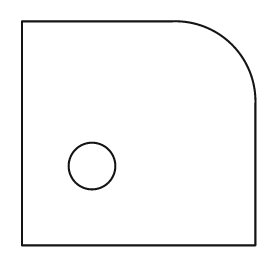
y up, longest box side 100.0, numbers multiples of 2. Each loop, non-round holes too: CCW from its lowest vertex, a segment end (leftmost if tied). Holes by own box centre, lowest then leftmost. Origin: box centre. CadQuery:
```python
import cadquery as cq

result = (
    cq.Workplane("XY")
    .moveTo(-50.0, -48.0)
    .lineTo(50.0, -48.0)
    .lineTo(50.0, 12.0)
    .threePointArc((40.0, 38.0), (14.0, 48.0))
    .lineTo(-50.0, 48.0)
    .close()
    .moveTo(-20.0, -14.0)
    .circle(10.0)
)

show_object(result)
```